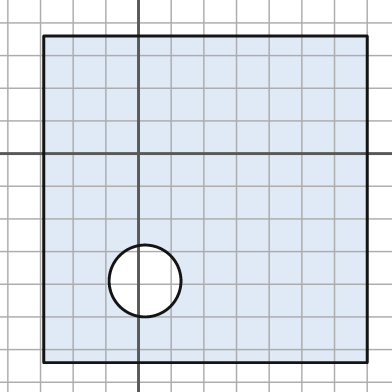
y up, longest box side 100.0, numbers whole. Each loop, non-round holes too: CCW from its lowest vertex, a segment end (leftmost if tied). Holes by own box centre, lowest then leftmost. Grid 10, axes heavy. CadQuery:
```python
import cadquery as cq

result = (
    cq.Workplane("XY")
    .moveTo(-29.0, -64.0)
    .lineTo(70.0, -64.0)
    .lineTo(70.0, 36.0)
    .lineTo(-29.0, 36.0)
    .close()
    .moveTo(2.0, -39.0)
    .circle(11.0)
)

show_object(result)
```